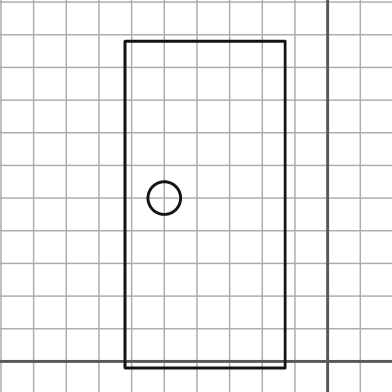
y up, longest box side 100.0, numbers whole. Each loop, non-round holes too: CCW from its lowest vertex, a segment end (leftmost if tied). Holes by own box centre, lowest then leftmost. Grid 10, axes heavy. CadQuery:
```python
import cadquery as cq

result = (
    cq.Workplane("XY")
    .moveTo(-62.0, -2.0)
    .lineTo(-13.0, -2.0)
    .lineTo(-13.0, 98.0)
    .lineTo(-62.0, 98.0)
    .close()
    .moveTo(-50.0, 50.0)
    .circle(5.0)
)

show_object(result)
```